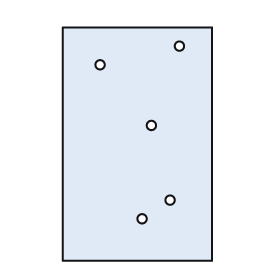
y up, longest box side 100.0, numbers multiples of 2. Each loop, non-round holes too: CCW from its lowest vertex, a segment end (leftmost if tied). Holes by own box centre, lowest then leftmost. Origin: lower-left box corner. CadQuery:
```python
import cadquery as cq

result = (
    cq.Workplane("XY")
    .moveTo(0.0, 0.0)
    .lineTo(64.0, 0.0)
    .lineTo(64.0, 100.0)
    .lineTo(0.0, 100.0)
    .close()
    .moveTo(34.0, 18.0)
    .circle(2.0)
    .moveTo(46.0, 26.0)
    .circle(2.0)
    .moveTo(38.0, 58.0)
    .circle(2.0)
    .moveTo(16.0, 84.0)
    .circle(2.0)
    .moveTo(50.0, 92.0)
    .circle(2.0)
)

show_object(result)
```